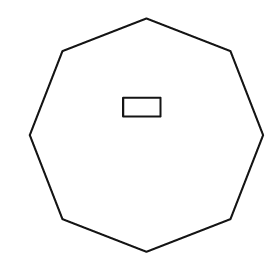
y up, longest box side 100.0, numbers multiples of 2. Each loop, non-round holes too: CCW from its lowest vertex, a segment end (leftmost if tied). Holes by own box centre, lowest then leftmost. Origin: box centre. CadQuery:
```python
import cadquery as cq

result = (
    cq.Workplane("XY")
    .moveTo(0.0, -50.0)
    .lineTo(36.0, -36.0)
    .lineTo(50.0, 0.0)
    .lineTo(36.0, 36.0)
    .lineTo(0.0, 50.0)
    .lineTo(-36.0, 36.0)
    .lineTo(-50.0, 0.0)
    .lineTo(-36.0, -36.0)
    .close()
    .moveTo(-10.0, 8.0)
    .lineTo(6.0, 8.0)
    .lineTo(6.0, 16.0)
    .lineTo(-10.0, 16.0)
    .close()
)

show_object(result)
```